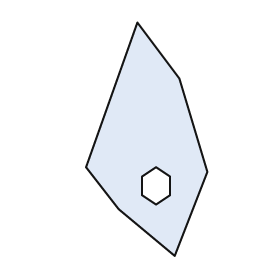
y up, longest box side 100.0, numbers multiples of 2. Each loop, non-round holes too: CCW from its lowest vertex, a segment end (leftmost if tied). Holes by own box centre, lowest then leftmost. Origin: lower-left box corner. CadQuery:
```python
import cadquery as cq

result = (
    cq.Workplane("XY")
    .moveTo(38.0, 0.0)
    .lineTo(52.0, 36.0)
    .lineTo(40.0, 76.0)
    .lineTo(22.0, 100.0)
    .lineTo(0.0, 38.0)
    .lineTo(14.0, 20.0)
    .close()
    .moveTo(30.0, 22.0)
    .lineTo(36.0, 26.0)
    .lineTo(36.0, 34.0)
    .lineTo(30.0, 38.0)
    .lineTo(24.0, 34.0)
    .lineTo(24.0, 26.0)
    .close()
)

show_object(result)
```